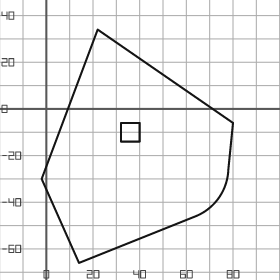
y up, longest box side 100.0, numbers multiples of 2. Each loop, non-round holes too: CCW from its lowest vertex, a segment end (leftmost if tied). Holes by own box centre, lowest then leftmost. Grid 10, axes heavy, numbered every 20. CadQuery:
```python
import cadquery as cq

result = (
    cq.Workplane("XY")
    .moveTo(14.0, -66.0)
    .lineTo(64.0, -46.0)
    .threePointArc((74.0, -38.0), (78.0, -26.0))
    .lineTo(80.0, -6.0)
    .lineTo(22.0, 34.0)
    .lineTo(-2.0, -30.0)
    .close()
    .moveTo(32.0, -14.0)
    .lineTo(40.0, -14.0)
    .lineTo(40.0, -6.0)
    .lineTo(32.0, -6.0)
    .close()
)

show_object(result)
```